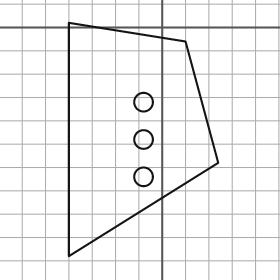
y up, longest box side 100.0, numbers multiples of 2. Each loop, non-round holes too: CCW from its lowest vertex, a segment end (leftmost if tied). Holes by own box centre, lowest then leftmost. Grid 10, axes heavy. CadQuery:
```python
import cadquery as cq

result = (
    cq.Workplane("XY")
    .moveTo(-40.0, -98.0)
    .lineTo(24.0, -58.0)
    .lineTo(10.0, -6.0)
    .lineTo(-40.0, 2.0)
    .close()
    .moveTo(-8.0, -64.0)
    .circle(4.0)
    .moveTo(-8.0, -48.0)
    .circle(4.0)
    .moveTo(-8.0, -32.0)
    .circle(4.0)
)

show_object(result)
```